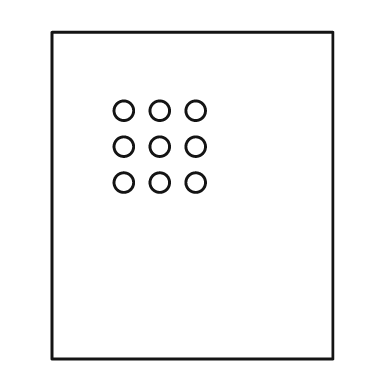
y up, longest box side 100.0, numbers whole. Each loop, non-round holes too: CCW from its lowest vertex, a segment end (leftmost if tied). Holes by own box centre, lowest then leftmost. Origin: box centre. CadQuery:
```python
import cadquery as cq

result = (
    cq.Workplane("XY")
    .moveTo(-43.0, -50.0)
    .lineTo(43.0, -50.0)
    .lineTo(43.0, 50.0)
    .lineTo(-43.0, 50.0)
    .close()
    .moveTo(-21.0, 4.0)
    .circle(3.0)
    .moveTo(-10.0, 4.0)
    .circle(3.0)
    .moveTo(1.0, 4.0)
    .circle(3.0)
    .moveTo(-21.0, 15.0)
    .circle(3.0)
    .moveTo(-10.0, 15.0)
    .circle(3.0)
    .moveTo(1.0, 15.0)
    .circle(3.0)
    .moveTo(-21.0, 26.0)
    .circle(3.0)
    .moveTo(-10.0, 26.0)
    .circle(3.0)
    .moveTo(1.0, 26.0)
    .circle(3.0)
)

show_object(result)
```